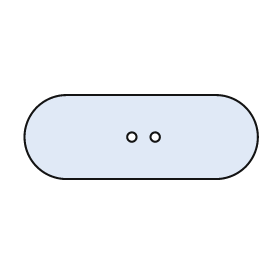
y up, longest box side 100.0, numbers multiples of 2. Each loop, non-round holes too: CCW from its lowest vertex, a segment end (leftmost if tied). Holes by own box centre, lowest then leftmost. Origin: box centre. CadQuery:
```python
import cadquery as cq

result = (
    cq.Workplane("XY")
    .moveTo(-32.0, -18.0)
    .lineTo(32.0, -18.0)
    .threePointArc((50.0, 0.0), (32.0, 18.0))
    .lineTo(-32.0, 18.0)
    .threePointArc((-50.0, 0.0), (-32.0, -18.0))
    .close()
    .moveTo(-4.0, 0.0)
    .circle(2.0)
    .moveTo(6.0, 0.0)
    .circle(2.0)
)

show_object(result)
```